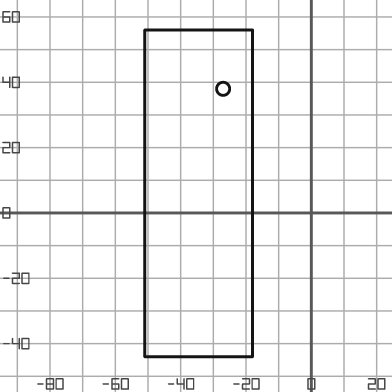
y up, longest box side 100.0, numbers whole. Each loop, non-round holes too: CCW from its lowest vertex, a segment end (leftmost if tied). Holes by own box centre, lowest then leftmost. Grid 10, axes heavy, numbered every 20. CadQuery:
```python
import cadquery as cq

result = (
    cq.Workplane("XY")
    .moveTo(-51.0, -44.0)
    .lineTo(-18.0, -44.0)
    .lineTo(-18.0, 56.0)
    .lineTo(-51.0, 56.0)
    .close()
    .moveTo(-27.0, 38.0)
    .circle(2.0)
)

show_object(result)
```